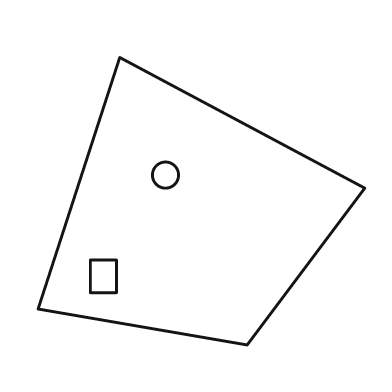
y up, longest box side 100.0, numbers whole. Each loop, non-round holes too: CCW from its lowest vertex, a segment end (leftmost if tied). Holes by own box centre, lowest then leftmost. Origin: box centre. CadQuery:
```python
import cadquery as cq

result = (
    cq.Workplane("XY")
    .moveTo(14.0, -44.0)
    .lineTo(50.0, 4.0)
    .lineTo(-25.0, 44.0)
    .lineTo(-50.0, -33.0)
    .close()
    .moveTo(-34.0, -28.0)
    .lineTo(-26.0, -28.0)
    .lineTo(-26.0, -18.0)
    .lineTo(-34.0, -18.0)
    .close()
    .moveTo(-11.0, 8.0)
    .circle(4.0)
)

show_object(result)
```